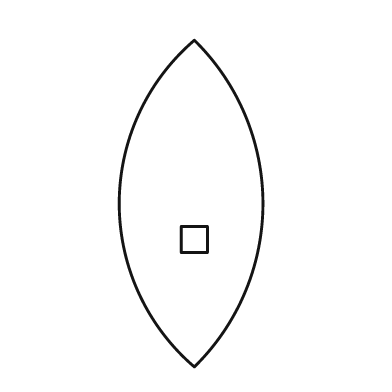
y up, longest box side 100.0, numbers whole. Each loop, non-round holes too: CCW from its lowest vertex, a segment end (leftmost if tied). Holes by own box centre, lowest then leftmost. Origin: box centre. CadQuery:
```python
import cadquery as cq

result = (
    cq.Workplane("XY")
    .moveTo(1.0, -50.0)
    .threePointArc((22.0, 0.0), (1.0, 50.0))
    .threePointArc((-22.0, 0.0), (1.0, -50.0))
    .close()
    .moveTo(-3.0, -15.0)
    .lineTo(5.0, -15.0)
    .lineTo(5.0, -7.0)
    .lineTo(-3.0, -7.0)
    .close()
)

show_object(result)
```